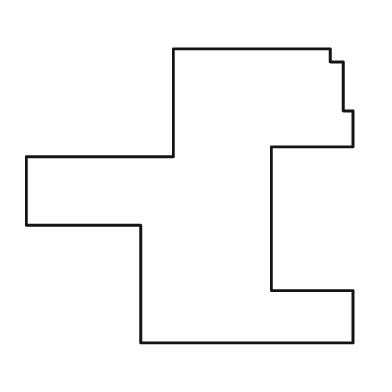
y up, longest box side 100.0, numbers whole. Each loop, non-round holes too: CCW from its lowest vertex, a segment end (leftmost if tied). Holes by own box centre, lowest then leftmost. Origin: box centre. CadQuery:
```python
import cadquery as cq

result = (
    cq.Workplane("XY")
    .moveTo(-15.0, -45.0)
    .lineTo(50.0, -45.0)
    .lineTo(50.0, -29.0)
    .lineTo(25.0, -29.0)
    .lineTo(25.0, 15.0)
    .lineTo(50.0, 15.0)
    .lineTo(50.0, 26.0)
    .lineTo(47.0, 26.0)
    .lineTo(47.0, 41.0)
    .lineTo(43.0, 41.0)
    .lineTo(43.0, 45.0)
    .lineTo(-5.0, 45.0)
    .lineTo(-5.0, 12.0)
    .lineTo(-50.0, 12.0)
    .lineTo(-50.0, -9.0)
    .lineTo(-15.0, -9.0)
    .close()
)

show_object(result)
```